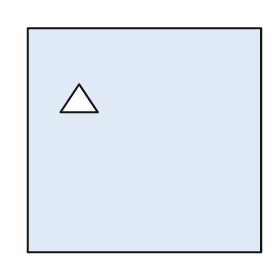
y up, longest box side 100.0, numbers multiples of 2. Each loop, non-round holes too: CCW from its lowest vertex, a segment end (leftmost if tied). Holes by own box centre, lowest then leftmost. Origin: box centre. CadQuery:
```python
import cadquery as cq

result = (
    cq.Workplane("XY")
    .moveTo(-50.0, -48.0)
    .lineTo(50.0, -48.0)
    .lineTo(50.0, 48.0)
    .lineTo(-50.0, 48.0)
    .close()
    .moveTo(-36.0, 12.0)
    .lineTo(-20.0, 12.0)
    .lineTo(-28.0, 24.0)
    .close()
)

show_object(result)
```